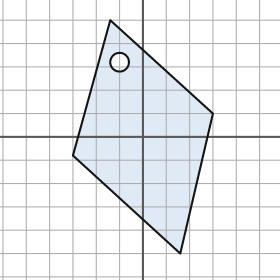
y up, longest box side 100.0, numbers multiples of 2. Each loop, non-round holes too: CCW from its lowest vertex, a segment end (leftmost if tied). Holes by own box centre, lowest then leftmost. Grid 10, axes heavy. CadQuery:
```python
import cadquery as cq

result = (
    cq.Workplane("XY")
    .moveTo(16.0, -50.0)
    .lineTo(30.0, 10.0)
    .lineTo(-14.0, 50.0)
    .lineTo(-30.0, -8.0)
    .close()
    .moveTo(-10.0, 32.0)
    .circle(4.0)
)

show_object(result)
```